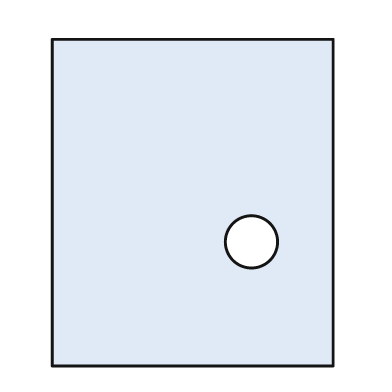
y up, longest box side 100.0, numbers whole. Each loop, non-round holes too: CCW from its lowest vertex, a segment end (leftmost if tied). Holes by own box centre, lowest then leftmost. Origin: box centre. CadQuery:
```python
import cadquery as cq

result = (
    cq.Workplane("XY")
    .moveTo(-43.0, -50.0)
    .lineTo(43.0, -50.0)
    .lineTo(43.0, 50.0)
    .lineTo(-43.0, 50.0)
    .close()
    .moveTo(18.0, -12.0)
    .circle(8.0)
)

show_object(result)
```